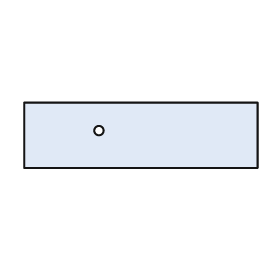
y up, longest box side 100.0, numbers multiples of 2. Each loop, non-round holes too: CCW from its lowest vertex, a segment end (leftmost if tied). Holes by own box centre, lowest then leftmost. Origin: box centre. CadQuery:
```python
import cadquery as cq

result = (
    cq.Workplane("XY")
    .moveTo(-50.0, -14.0)
    .lineTo(50.0, -14.0)
    .lineTo(50.0, 14.0)
    .lineTo(-50.0, 14.0)
    .close()
    .moveTo(-18.0, 2.0)
    .circle(2.0)
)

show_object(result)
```